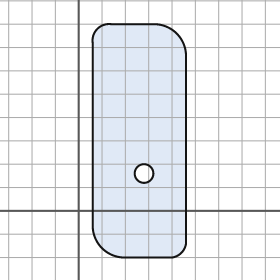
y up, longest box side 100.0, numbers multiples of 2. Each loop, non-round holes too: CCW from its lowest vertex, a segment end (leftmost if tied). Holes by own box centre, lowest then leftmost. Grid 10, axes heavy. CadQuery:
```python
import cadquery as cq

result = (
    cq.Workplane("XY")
    .moveTo(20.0, -20.0)
    .lineTo(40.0, -20.0)
    .threePointArc((44.0, -18.0), (46.0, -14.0))
    .lineTo(46.0, 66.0)
    .threePointArc((42.0, 76.0), (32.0, 80.0))
    .lineTo(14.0, 80.0)
    .threePointArc((8.0, 78.0), (6.0, 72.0))
    .lineTo(6.0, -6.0)
    .threePointArc((10.0, -16.0), (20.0, -20.0))
    .close()
    .moveTo(28.0, 16.0)
    .circle(4.0)
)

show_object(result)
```